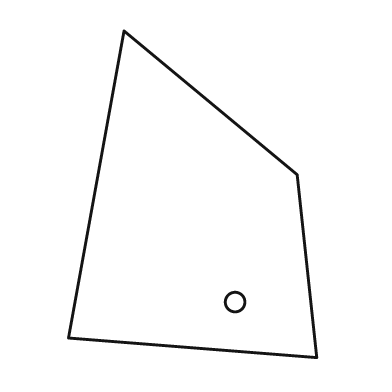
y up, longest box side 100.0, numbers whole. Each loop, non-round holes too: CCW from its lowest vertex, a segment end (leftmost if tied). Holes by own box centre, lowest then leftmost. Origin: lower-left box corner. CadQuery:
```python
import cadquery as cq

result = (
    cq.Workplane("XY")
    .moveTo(76.0, 0.0)
    .lineTo(70.0, 56.0)
    .lineTo(17.0, 100.0)
    .lineTo(0.0, 6.0)
    .close()
    .moveTo(51.0, 17.0)
    .circle(3.0)
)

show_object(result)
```